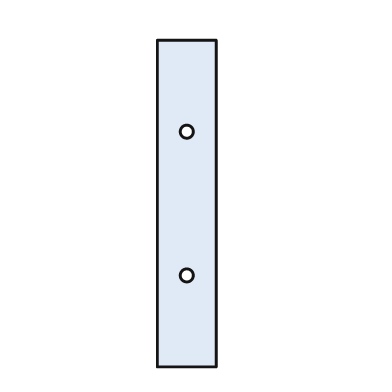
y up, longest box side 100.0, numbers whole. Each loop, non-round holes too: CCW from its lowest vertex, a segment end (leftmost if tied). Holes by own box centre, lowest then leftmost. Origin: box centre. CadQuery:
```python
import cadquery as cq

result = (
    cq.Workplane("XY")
    .moveTo(-9.0, -50.0)
    .lineTo(9.0, -50.0)
    .lineTo(9.0, 50.0)
    .lineTo(-9.0, 50.0)
    .close()
    .moveTo(0.0, -22.0)
    .circle(2.0)
    .moveTo(0.0, 22.0)
    .circle(2.0)
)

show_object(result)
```